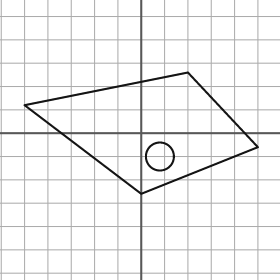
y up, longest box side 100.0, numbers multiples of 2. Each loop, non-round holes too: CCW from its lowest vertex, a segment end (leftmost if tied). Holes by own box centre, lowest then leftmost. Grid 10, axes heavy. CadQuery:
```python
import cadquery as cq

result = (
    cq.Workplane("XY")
    .moveTo(0.0, -26.0)
    .lineTo(50.0, -6.0)
    .lineTo(20.0, 26.0)
    .lineTo(-50.0, 12.0)
    .close()
    .moveTo(8.0, -10.0)
    .circle(6.0)
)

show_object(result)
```